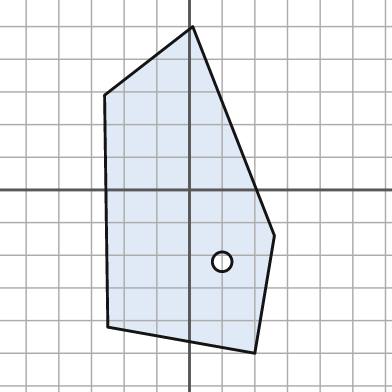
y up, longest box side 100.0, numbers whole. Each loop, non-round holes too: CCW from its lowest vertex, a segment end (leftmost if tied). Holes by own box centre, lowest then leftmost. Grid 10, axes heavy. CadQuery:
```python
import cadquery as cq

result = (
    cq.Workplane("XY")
    .moveTo(20.0, -50.0)
    .lineTo(26.0, -14.0)
    .lineTo(1.0, 50.0)
    .lineTo(-26.0, 29.0)
    .lineTo(-25.0, -42.0)
    .close()
    .moveTo(10.0, -22.0)
    .circle(3.0)
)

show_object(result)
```